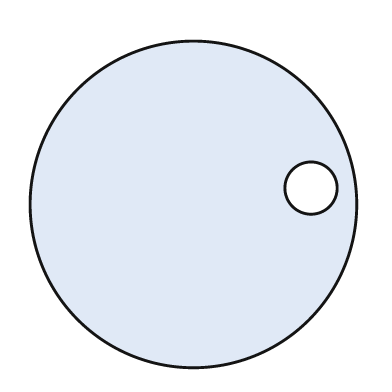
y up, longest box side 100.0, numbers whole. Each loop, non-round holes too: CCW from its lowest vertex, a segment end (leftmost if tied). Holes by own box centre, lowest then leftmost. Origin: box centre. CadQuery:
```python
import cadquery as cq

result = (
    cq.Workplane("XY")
    .moveTo(0.0, 0.0)
    .circle(50.0)
    .moveTo(36.0, 5.0)
    .circle(8.0)
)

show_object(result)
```